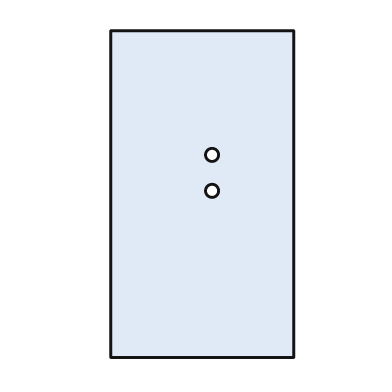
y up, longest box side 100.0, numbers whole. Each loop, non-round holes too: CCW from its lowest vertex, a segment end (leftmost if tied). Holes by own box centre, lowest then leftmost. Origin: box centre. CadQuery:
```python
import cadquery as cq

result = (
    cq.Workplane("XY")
    .moveTo(-28.0, -50.0)
    .lineTo(28.0, -50.0)
    .lineTo(28.0, 50.0)
    .lineTo(-28.0, 50.0)
    .close()
    .moveTo(3.0, 1.0)
    .circle(2.0)
    .moveTo(3.0, 12.0)
    .circle(2.0)
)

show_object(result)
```